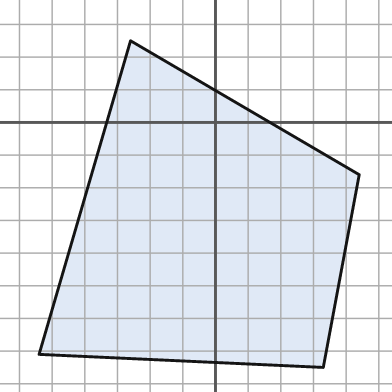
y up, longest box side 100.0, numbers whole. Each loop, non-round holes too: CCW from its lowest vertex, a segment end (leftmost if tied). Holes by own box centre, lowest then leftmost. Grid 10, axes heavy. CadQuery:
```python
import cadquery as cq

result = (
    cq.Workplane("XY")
    .moveTo(33.0, -75.0)
    .lineTo(44.0, -16.0)
    .lineTo(-26.0, 25.0)
    .lineTo(-54.0, -71.0)
    .close()
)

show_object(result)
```